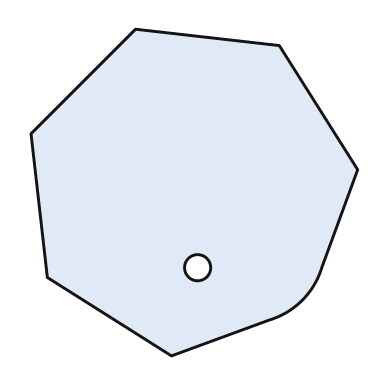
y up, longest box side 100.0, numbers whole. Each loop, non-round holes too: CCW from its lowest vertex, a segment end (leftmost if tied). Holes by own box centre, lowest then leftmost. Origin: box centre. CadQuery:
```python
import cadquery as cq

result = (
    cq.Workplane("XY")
    .moveTo(-7.0, -50.0)
    .lineTo(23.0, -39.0)
    .threePointArc((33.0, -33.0), (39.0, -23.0))
    .lineTo(50.0, 7.0)
    .lineTo(26.0, 45.0)
    .lineTo(-18.0, 50.0)
    .lineTo(-50.0, 18.0)
    .lineTo(-45.0, -26.0)
    .close()
    .moveTo(1.0, -23.0)
    .circle(4.0)
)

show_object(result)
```